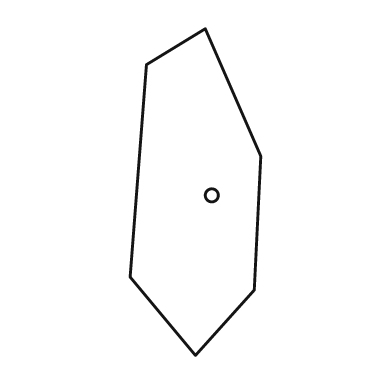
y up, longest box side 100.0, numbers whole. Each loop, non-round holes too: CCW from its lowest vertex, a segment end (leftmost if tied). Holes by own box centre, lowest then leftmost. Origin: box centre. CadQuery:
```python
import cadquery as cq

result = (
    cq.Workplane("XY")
    .moveTo(0.0, -50.0)
    .lineTo(18.0, -30.0)
    .lineTo(20.0, 11.0)
    .lineTo(3.0, 50.0)
    .lineTo(-15.0, 39.0)
    .lineTo(-20.0, -26.0)
    .close()
    .moveTo(5.0, -1.0)
    .circle(2.0)
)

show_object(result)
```